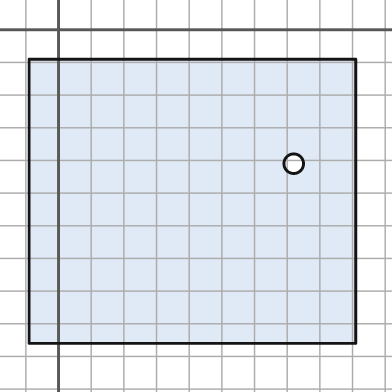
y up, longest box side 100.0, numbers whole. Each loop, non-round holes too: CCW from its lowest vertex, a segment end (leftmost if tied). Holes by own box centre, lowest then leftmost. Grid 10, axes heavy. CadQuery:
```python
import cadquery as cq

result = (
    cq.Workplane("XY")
    .moveTo(-9.0, -96.0)
    .lineTo(91.0, -96.0)
    .lineTo(91.0, -9.0)
    .lineTo(-9.0, -9.0)
    .close()
    .moveTo(72.0, -41.0)
    .circle(3.0)
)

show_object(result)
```